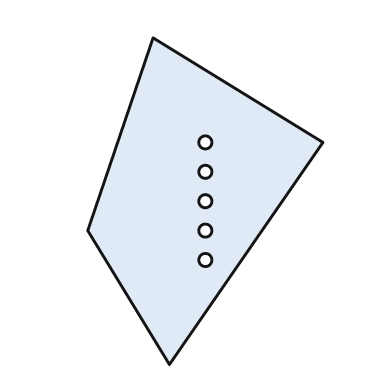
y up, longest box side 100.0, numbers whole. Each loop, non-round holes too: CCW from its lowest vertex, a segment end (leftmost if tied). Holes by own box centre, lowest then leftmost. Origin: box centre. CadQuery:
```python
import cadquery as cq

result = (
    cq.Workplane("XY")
    .moveTo(-11.0, -50.0)
    .lineTo(36.0, 18.0)
    .lineTo(-16.0, 50.0)
    .lineTo(-36.0, -9.0)
    .close()
    .moveTo(0.0, -18.0)
    .circle(2.0)
    .moveTo(0.0, -9.0)
    .circle(2.0)
    .moveTo(0.0, 0.0)
    .circle(2.0)
    .moveTo(0.0, 9.0)
    .circle(2.0)
    .moveTo(0.0, 18.0)
    .circle(2.0)
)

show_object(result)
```